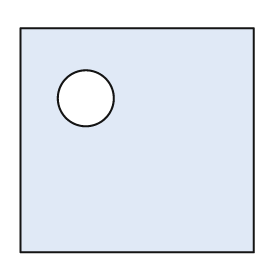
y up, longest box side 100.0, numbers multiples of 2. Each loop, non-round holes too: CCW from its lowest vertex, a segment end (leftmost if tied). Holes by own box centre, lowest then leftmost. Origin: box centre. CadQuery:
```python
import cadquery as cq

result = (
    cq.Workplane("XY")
    .moveTo(-50.0, -48.0)
    .lineTo(50.0, -48.0)
    .lineTo(50.0, 48.0)
    .lineTo(-50.0, 48.0)
    .close()
    .moveTo(-22.0, 18.0)
    .circle(12.0)
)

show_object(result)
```